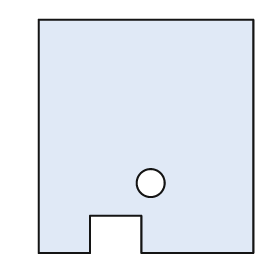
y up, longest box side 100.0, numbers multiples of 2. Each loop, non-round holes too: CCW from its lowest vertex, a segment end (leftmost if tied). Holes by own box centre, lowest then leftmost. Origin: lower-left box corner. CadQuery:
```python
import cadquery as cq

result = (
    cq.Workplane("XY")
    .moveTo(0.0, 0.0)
    .lineTo(22.0, 0.0)
    .lineTo(22.0, 16.0)
    .lineTo(44.0, 16.0)
    .lineTo(44.0, 0.0)
    .lineTo(92.0, 0.0)
    .lineTo(92.0, 100.0)
    .lineTo(0.0, 100.0)
    .close()
    .moveTo(48.0, 30.0)
    .circle(6.0)
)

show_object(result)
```